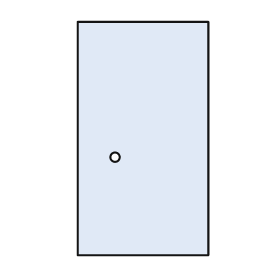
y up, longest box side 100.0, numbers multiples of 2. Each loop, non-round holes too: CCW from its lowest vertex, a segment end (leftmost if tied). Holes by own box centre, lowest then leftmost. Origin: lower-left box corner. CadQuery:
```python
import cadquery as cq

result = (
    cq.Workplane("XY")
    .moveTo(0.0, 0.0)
    .lineTo(56.0, 0.0)
    .lineTo(56.0, 100.0)
    .lineTo(0.0, 100.0)
    .close()
    .moveTo(16.0, 42.0)
    .circle(2.0)
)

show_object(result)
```